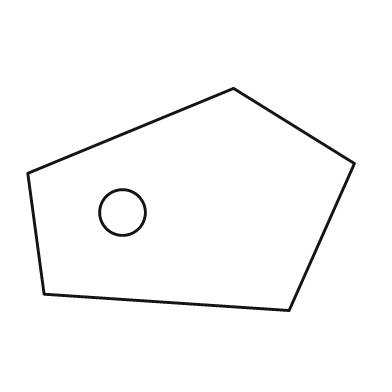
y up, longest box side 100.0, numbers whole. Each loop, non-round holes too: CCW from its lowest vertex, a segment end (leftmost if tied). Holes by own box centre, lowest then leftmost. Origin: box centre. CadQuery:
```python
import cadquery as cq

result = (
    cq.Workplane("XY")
    .moveTo(30.0, -34.0)
    .lineTo(50.0, 11.0)
    .lineTo(13.0, 34.0)
    .lineTo(-50.0, 8.0)
    .lineTo(-45.0, -29.0)
    .close()
    .moveTo(-21.0, -4.0)
    .circle(7.0)
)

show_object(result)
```